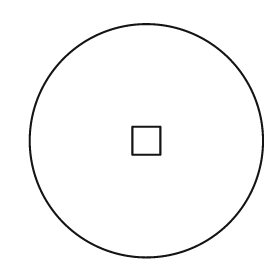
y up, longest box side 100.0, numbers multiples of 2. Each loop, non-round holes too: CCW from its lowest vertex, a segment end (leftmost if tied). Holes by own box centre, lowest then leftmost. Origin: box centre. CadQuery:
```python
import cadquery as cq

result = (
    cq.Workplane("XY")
    .moveTo(0.0, 0.0)
    .circle(50.0)
    .moveTo(-6.0, -6.0)
    .lineTo(6.0, -6.0)
    .lineTo(6.0, 6.0)
    .lineTo(-6.0, 6.0)
    .close()
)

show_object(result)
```